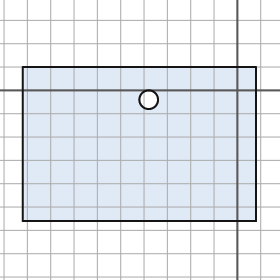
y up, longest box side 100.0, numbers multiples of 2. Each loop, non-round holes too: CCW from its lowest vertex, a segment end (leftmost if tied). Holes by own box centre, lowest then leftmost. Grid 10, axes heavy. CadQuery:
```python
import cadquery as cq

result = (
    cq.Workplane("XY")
    .moveTo(-92.0, -56.0)
    .lineTo(8.0, -56.0)
    .lineTo(8.0, 10.0)
    .lineTo(-92.0, 10.0)
    .close()
    .moveTo(-38.0, -4.0)
    .circle(4.0)
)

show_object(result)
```